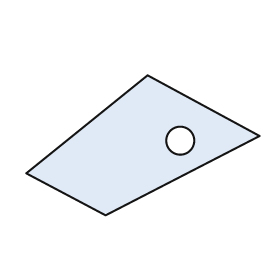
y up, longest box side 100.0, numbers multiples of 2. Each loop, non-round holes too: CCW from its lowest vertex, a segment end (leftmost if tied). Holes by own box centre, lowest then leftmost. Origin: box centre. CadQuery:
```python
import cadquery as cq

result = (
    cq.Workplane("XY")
    .moveTo(-16.0, -30.0)
    .lineTo(50.0, 4.0)
    .lineTo(2.0, 30.0)
    .lineTo(-50.0, -12.0)
    .close()
    .moveTo(16.0, 2.0)
    .circle(6.0)
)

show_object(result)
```